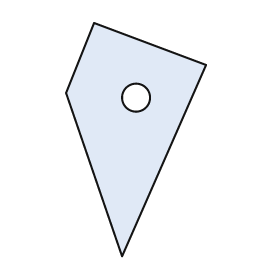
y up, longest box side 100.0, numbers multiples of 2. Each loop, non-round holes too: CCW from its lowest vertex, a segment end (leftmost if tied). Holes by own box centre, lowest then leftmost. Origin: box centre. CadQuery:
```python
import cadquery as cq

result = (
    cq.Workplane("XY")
    .moveTo(-6.0, -50.0)
    .lineTo(30.0, 32.0)
    .lineTo(-18.0, 50.0)
    .lineTo(-30.0, 20.0)
    .close()
    .moveTo(0.0, 18.0)
    .circle(6.0)
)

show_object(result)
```